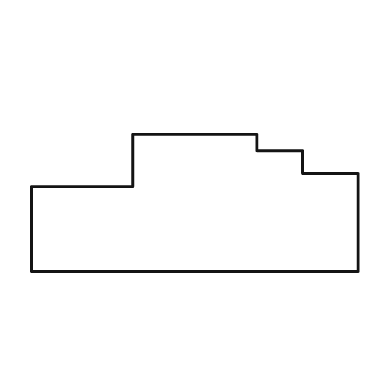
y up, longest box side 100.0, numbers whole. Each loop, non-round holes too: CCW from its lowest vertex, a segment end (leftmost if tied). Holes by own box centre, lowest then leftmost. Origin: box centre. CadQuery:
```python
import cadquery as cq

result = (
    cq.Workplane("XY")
    .moveTo(-50.0, -21.0)
    .lineTo(50.0, -21.0)
    .lineTo(50.0, 9.0)
    .lineTo(33.0, 9.0)
    .lineTo(33.0, 16.0)
    .lineTo(19.0, 16.0)
    .lineTo(19.0, 21.0)
    .lineTo(-19.0, 21.0)
    .lineTo(-19.0, 5.0)
    .lineTo(-50.0, 5.0)
    .close()
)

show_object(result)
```